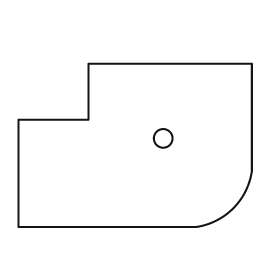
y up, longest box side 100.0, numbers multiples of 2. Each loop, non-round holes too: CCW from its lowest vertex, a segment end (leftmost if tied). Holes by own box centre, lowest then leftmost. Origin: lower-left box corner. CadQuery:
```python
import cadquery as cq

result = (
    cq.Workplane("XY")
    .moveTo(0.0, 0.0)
    .lineTo(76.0, 0.0)
    .threePointArc((92.0, 8.0), (100.0, 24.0))
    .lineTo(100.0, 70.0)
    .lineTo(30.0, 70.0)
    .lineTo(30.0, 46.0)
    .lineTo(0.0, 46.0)
    .close()
    .moveTo(62.0, 38.0)
    .circle(4.0)
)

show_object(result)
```